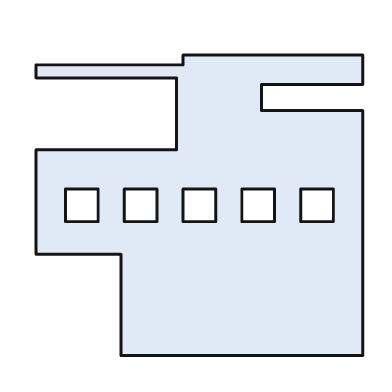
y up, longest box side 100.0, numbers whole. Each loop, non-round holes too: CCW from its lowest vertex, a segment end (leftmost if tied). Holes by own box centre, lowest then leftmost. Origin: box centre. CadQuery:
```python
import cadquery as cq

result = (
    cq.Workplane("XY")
    .moveTo(-24.0, -46.0)
    .lineTo(50.0, -46.0)
    .lineTo(50.0, 29.0)
    .lineTo(19.0, 29.0)
    .lineTo(19.0, 37.0)
    .lineTo(50.0, 37.0)
    .lineTo(50.0, 46.0)
    .lineTo(-5.0, 46.0)
    .lineTo(-5.0, 43.0)
    .lineTo(-50.0, 43.0)
    .lineTo(-50.0, 39.0)
    .lineTo(-7.0, 39.0)
    .lineTo(-7.0, 17.0)
    .lineTo(-50.0, 17.0)
    .lineTo(-50.0, -15.0)
    .lineTo(-24.0, -15.0)
    .close()
    .moveTo(-41.0, -5.0)
    .lineTo(-31.0, -5.0)
    .lineTo(-31.0, 5.0)
    .lineTo(-41.0, 5.0)
    .close()
    .moveTo(-23.0, -5.0)
    .lineTo(-13.0, -5.0)
    .lineTo(-13.0, 5.0)
    .lineTo(-23.0, 5.0)
    .close()
    .moveTo(-5.0, -5.0)
    .lineTo(5.0, -5.0)
    .lineTo(5.0, 5.0)
    .lineTo(-5.0, 5.0)
    .close()
    .moveTo(13.0, -5.0)
    .lineTo(23.0, -5.0)
    .lineTo(23.0, 5.0)
    .lineTo(13.0, 5.0)
    .close()
    .moveTo(31.0, -5.0)
    .lineTo(41.0, -5.0)
    .lineTo(41.0, 5.0)
    .lineTo(31.0, 5.0)
    .close()
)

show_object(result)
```